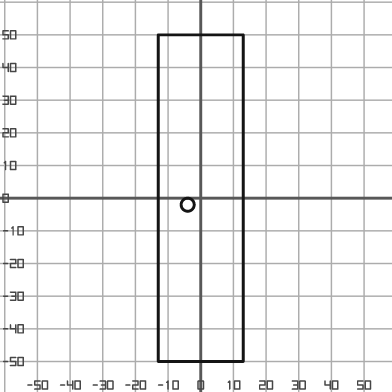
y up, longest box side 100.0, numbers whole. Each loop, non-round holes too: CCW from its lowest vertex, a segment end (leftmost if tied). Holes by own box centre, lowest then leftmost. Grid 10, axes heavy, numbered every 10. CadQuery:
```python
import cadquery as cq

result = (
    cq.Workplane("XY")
    .moveTo(-13.0, -50.0)
    .lineTo(13.0, -50.0)
    .lineTo(13.0, 50.0)
    .lineTo(-13.0, 50.0)
    .close()
    .moveTo(-4.0, -2.0)
    .circle(2.0)
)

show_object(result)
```